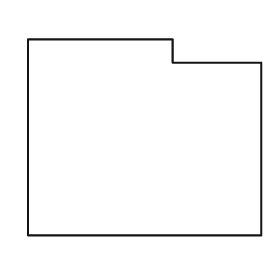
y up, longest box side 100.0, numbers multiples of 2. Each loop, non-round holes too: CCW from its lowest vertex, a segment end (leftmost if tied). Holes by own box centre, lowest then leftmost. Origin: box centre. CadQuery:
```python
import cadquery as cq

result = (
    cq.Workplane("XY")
    .moveTo(-50.0, -42.0)
    .lineTo(50.0, -42.0)
    .lineTo(50.0, 32.0)
    .lineTo(12.0, 32.0)
    .lineTo(12.0, 42.0)
    .lineTo(-50.0, 42.0)
    .close()
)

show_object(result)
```